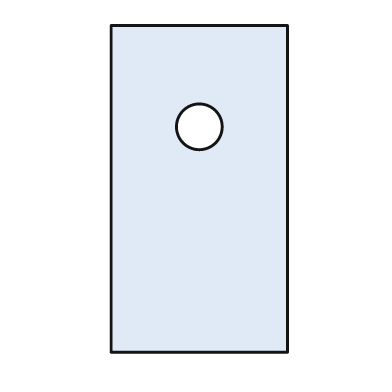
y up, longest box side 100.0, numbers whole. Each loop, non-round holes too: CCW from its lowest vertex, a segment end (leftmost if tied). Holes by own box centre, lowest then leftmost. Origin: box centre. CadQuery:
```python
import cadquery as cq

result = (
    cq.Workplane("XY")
    .moveTo(-27.0, -50.0)
    .lineTo(27.0, -50.0)
    .lineTo(27.0, 50.0)
    .lineTo(-27.0, 50.0)
    .close()
    .moveTo(0.0, 19.0)
    .circle(7.0)
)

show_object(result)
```